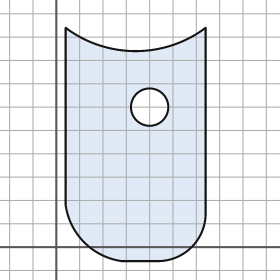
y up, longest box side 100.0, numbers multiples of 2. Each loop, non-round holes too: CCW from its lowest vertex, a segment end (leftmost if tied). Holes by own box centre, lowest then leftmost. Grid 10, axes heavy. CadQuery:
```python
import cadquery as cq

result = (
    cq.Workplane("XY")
    .moveTo(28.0, -6.0)
    .lineTo(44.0, -6.0)
    .threePointArc((58.0, 0.0), (64.0, 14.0))
    .lineTo(64.0, 94.0)
    .threePointArc((34.0, 84.0), (4.0, 94.0))
    .lineTo(4.0, 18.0)
    .threePointArc((12.0, 2.0), (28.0, -6.0))
    .close()
    .moveTo(40.0, 60.0)
    .circle(8.0)
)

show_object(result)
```